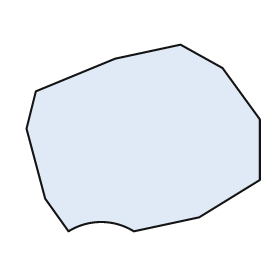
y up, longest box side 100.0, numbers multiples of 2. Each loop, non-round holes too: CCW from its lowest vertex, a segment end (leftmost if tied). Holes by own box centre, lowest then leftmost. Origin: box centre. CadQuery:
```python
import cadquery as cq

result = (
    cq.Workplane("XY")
    .moveTo(-32.0, -40.0)
    .threePointArc((-18.0, -36.0), (-4.0, -40.0))
    .lineTo(24.0, -34.0)
    .lineTo(50.0, -18.0)
    .lineTo(50.0, 8.0)
    .lineTo(34.0, 30.0)
    .lineTo(16.0, 40.0)
    .lineTo(-12.0, 34.0)
    .lineTo(-46.0, 20.0)
    .lineTo(-50.0, 4.0)
    .lineTo(-42.0, -26.0)
    .close()
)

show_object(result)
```